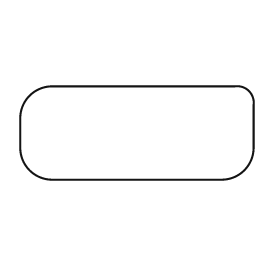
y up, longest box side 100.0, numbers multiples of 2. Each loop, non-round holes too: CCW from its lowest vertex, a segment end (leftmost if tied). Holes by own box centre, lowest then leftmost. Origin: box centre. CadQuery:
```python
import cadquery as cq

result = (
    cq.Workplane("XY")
    .moveTo(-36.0, -20.0)
    .lineTo(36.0, -20.0)
    .threePointArc((46.0, -16.0), (50.0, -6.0))
    .lineTo(50.0, 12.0)
    .threePointArc((48.0, 18.0), (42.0, 20.0))
    .lineTo(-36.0, 20.0)
    .threePointArc((-46.0, 16.0), (-50.0, 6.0))
    .lineTo(-50.0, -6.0)
    .threePointArc((-46.0, -16.0), (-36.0, -20.0))
    .close()
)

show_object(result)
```